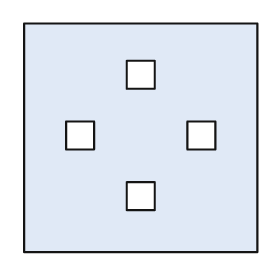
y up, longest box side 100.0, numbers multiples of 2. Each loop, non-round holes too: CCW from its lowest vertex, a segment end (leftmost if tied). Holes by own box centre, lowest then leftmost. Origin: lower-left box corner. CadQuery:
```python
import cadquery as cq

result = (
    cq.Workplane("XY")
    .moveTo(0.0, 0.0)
    .lineTo(100.0, 0.0)
    .lineTo(100.0, 98.0)
    .lineTo(0.0, 98.0)
    .close()
    .moveTo(44.0, 18.0)
    .lineTo(56.0, 18.0)
    .lineTo(56.0, 30.0)
    .lineTo(44.0, 30.0)
    .close()
    .moveTo(18.0, 44.0)
    .lineTo(30.0, 44.0)
    .lineTo(30.0, 56.0)
    .lineTo(18.0, 56.0)
    .close()
    .moveTo(70.0, 44.0)
    .lineTo(82.0, 44.0)
    .lineTo(82.0, 56.0)
    .lineTo(70.0, 56.0)
    .close()
    .moveTo(44.0, 70.0)
    .lineTo(56.0, 70.0)
    .lineTo(56.0, 82.0)
    .lineTo(44.0, 82.0)
    .close()
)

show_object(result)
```